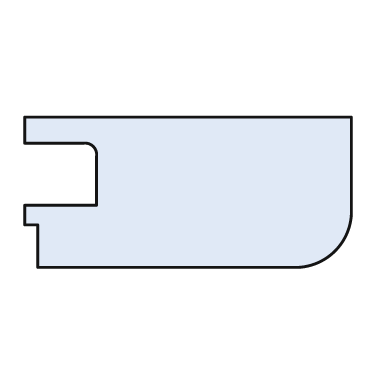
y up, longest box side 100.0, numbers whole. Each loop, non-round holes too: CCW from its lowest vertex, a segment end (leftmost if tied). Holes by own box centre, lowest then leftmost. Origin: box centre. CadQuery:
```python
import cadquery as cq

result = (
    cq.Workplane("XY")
    .moveTo(-46.0, -23.0)
    .lineTo(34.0, -23.0)
    .threePointArc((45.0, -18.0), (50.0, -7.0))
    .lineTo(50.0, 23.0)
    .lineTo(-50.0, 23.0)
    .lineTo(-50.0, 15.0)
    .lineTo(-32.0, 15.0)
    .threePointArc((-29.0, 14.0), (-28.0, 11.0))
    .lineTo(-28.0, -4.0)
    .lineTo(-50.0, -4.0)
    .lineTo(-50.0, -10.0)
    .lineTo(-46.0, -10.0)
    .close()
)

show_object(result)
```